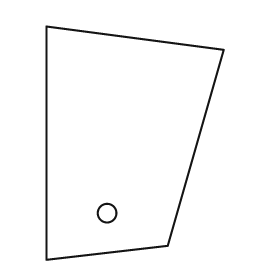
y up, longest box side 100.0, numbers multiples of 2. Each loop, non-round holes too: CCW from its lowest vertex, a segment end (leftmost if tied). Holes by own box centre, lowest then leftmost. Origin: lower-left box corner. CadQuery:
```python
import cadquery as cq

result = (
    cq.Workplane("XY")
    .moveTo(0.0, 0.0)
    .lineTo(52.0, 6.0)
    .lineTo(76.0, 90.0)
    .lineTo(0.0, 100.0)
    .close()
    .moveTo(26.0, 20.0)
    .circle(4.0)
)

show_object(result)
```